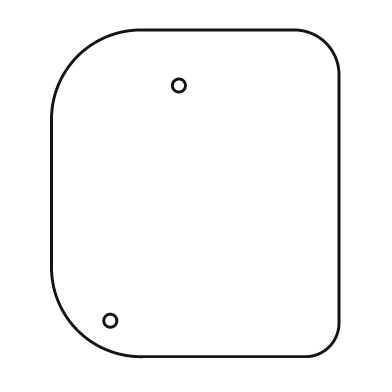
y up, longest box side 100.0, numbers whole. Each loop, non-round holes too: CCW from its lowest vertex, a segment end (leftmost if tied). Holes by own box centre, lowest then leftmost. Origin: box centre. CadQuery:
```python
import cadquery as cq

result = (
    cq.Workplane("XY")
    .moveTo(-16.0, -50.0)
    .lineTo(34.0, -50.0)
    .threePointArc((41.0, -47.0), (44.0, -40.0))
    .lineTo(44.0, 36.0)
    .threePointArc((40.0, 46.0), (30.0, 50.0))
    .lineTo(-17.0, 50.0)
    .threePointArc((-36.0, 42.0), (-44.0, 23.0))
    .lineTo(-44.0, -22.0)
    .threePointArc((-36.0, -42.0), (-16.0, -50.0))
    .close()
    .moveTo(-26.0, -39.0)
    .circle(2.0)
    .moveTo(-5.0, 33.0)
    .circle(2.0)
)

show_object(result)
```